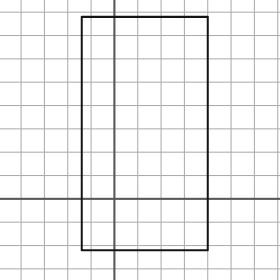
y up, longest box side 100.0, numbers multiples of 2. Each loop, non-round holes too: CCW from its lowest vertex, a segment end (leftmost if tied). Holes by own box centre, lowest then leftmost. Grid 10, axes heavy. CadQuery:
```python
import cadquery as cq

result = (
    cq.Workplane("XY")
    .moveTo(-14.0, -22.0)
    .lineTo(40.0, -22.0)
    .lineTo(40.0, 78.0)
    .lineTo(-14.0, 78.0)
    .close()
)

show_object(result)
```